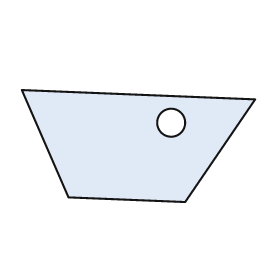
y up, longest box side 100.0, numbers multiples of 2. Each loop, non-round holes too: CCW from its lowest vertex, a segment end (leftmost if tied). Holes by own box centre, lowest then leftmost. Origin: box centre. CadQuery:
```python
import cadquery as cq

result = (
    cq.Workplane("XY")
    .moveTo(20.0, -24.0)
    .lineTo(50.0, 20.0)
    .lineTo(-50.0, 24.0)
    .lineTo(-30.0, -22.0)
    .close()
    .moveTo(14.0, 10.0)
    .circle(6.0)
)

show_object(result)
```